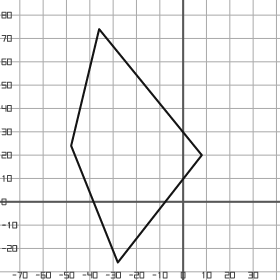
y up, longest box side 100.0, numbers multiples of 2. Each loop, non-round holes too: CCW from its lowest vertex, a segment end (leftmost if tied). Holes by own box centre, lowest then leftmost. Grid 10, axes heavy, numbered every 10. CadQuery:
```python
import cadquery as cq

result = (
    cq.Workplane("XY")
    .moveTo(-28.0, -26.0)
    .lineTo(8.0, 20.0)
    .lineTo(-36.0, 74.0)
    .lineTo(-48.0, 24.0)
    .close()
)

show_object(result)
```